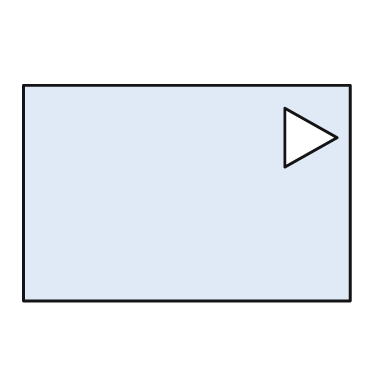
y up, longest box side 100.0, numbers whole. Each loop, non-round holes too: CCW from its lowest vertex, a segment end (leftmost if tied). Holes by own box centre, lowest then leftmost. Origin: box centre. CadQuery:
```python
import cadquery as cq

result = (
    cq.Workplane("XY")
    .moveTo(-50.0, -33.0)
    .lineTo(50.0, -33.0)
    .lineTo(50.0, 33.0)
    .lineTo(-50.0, 33.0)
    .close()
    .moveTo(30.0, 8.0)
    .lineTo(46.0, 17.0)
    .lineTo(30.0, 26.0)
    .close()
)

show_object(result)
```